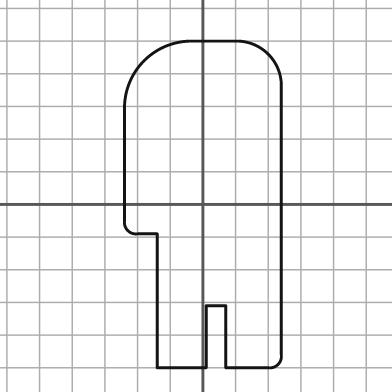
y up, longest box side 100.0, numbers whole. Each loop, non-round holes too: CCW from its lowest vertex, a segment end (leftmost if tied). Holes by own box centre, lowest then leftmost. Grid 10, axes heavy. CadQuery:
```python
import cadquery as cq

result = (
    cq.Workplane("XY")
    .moveTo(-14.0, -50.0)
    .lineTo(1.0, -50.0)
    .lineTo(1.0, -31.0)
    .lineTo(7.0, -31.0)
    .lineTo(7.0, -50.0)
    .lineTo(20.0, -50.0)
    .threePointArc((23.0, -49.0), (24.0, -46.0))
    .lineTo(24.0, 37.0)
    .threePointArc((20.0, 46.0), (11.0, 50.0))
    .lineTo(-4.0, 50.0)
    .threePointArc((-18.0, 44.0), (-24.0, 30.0))
    .lineTo(-24.0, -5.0)
    .threePointArc((-23.0, -8.0), (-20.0, -9.0))
    .lineTo(-14.0, -9.0)
    .close()
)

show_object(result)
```